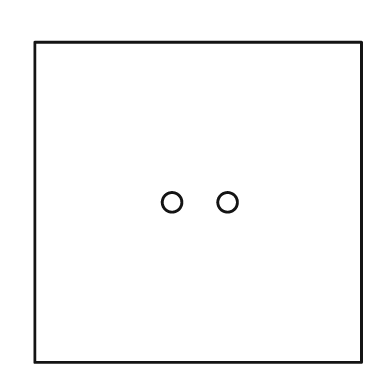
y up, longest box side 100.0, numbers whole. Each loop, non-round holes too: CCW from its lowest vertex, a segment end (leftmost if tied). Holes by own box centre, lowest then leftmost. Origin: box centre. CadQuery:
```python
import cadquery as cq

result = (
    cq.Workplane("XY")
    .moveTo(-50.0, -49.0)
    .lineTo(50.0, -49.0)
    .lineTo(50.0, 49.0)
    .lineTo(-50.0, 49.0)
    .close()
    .moveTo(-8.0, 0.0)
    .circle(3.0)
    .moveTo(9.0, 0.0)
    .circle(3.0)
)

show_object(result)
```